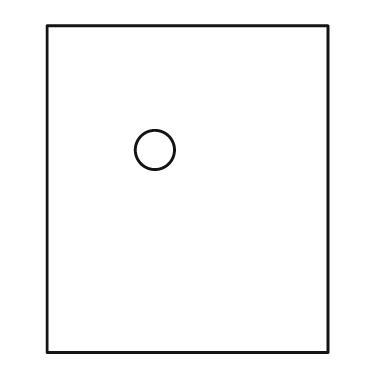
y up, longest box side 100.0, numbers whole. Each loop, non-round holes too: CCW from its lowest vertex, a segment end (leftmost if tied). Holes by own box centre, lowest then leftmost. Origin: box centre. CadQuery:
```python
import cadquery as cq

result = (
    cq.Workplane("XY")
    .moveTo(-43.0, -50.0)
    .lineTo(43.0, -50.0)
    .lineTo(43.0, 50.0)
    .lineTo(-43.0, 50.0)
    .close()
    .moveTo(-10.0, 12.0)
    .circle(6.0)
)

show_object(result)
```